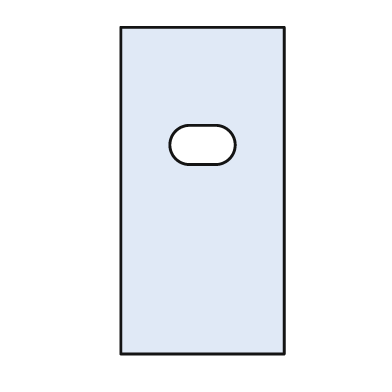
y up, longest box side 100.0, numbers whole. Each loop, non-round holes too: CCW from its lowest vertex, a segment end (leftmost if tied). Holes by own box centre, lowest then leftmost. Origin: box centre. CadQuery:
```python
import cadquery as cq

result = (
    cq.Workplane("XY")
    .moveTo(-25.0, -50.0)
    .lineTo(25.0, -50.0)
    .lineTo(25.0, 50.0)
    .lineTo(-25.0, 50.0)
    .close()
    .moveTo(-4.0, 8.0)
    .lineTo(4.0, 8.0)
    .threePointArc((10.0, 14.0), (4.0, 20.0))
    .lineTo(-4.0, 20.0)
    .threePointArc((-10.0, 14.0), (-4.0, 8.0))
    .close()
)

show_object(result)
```